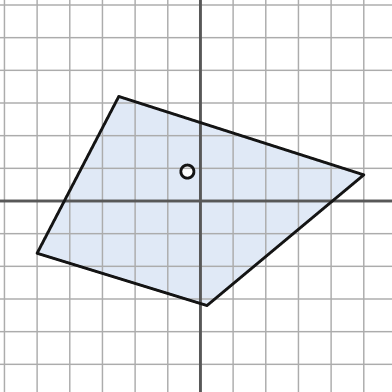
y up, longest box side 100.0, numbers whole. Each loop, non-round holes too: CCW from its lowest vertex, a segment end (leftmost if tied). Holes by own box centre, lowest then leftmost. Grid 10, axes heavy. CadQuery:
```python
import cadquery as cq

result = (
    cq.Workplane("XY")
    .moveTo(2.0, -32.0)
    .lineTo(50.0, 8.0)
    .lineTo(-25.0, 32.0)
    .lineTo(-50.0, -16.0)
    .close()
    .moveTo(-4.0, 9.0)
    .circle(2.0)
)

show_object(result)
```